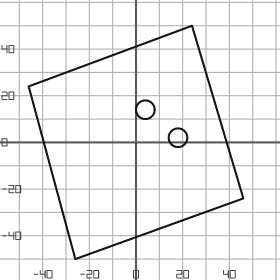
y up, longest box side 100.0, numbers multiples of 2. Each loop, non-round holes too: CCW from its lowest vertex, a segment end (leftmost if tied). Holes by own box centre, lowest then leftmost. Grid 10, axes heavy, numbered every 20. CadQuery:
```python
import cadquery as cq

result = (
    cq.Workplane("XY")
    .moveTo(-26.0, -50.0)
    .lineTo(46.0, -24.0)
    .lineTo(24.0, 50.0)
    .lineTo(-46.0, 24.0)
    .close()
    .moveTo(18.0, 2.0)
    .circle(4.0)
    .moveTo(4.0, 14.0)
    .circle(4.0)
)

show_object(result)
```